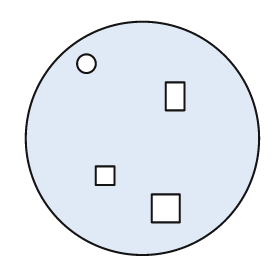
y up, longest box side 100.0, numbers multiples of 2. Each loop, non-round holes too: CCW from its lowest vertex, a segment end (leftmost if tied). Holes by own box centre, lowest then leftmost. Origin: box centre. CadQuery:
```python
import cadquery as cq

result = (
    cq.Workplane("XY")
    .moveTo(0.0, 0.0)
    .circle(50.0)
    .moveTo(4.0, -36.0)
    .lineTo(16.0, -36.0)
    .lineTo(16.0, -24.0)
    .lineTo(4.0, -24.0)
    .close()
    .moveTo(-20.0, -20.0)
    .lineTo(-12.0, -20.0)
    .lineTo(-12.0, -12.0)
    .lineTo(-20.0, -12.0)
    .close()
    .moveTo(10.0, 12.0)
    .lineTo(18.0, 12.0)
    .lineTo(18.0, 24.0)
    .lineTo(10.0, 24.0)
    .close()
    .moveTo(-24.0, 32.0)
    .circle(4.0)
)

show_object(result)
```